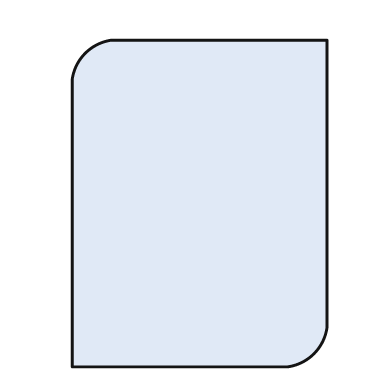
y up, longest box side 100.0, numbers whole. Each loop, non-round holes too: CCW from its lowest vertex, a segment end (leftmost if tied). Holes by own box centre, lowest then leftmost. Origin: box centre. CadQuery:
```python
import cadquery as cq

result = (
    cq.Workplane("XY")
    .moveTo(-39.0, -50.0)
    .lineTo(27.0, -50.0)
    .threePointArc((35.0, -46.0), (39.0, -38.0))
    .lineTo(39.0, 50.0)
    .lineTo(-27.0, 50.0)
    .threePointArc((-35.0, 46.0), (-39.0, 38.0))
    .close()
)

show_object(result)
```